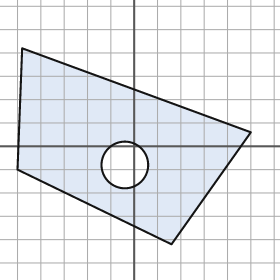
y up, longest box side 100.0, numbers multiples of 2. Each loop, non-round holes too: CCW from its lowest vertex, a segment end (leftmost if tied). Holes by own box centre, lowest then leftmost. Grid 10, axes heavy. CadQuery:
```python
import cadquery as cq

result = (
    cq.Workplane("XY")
    .moveTo(16.0, -42.0)
    .lineTo(50.0, 6.0)
    .lineTo(-48.0, 42.0)
    .lineTo(-50.0, -10.0)
    .close()
    .moveTo(-4.0, -8.0)
    .circle(10.0)
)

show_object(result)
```